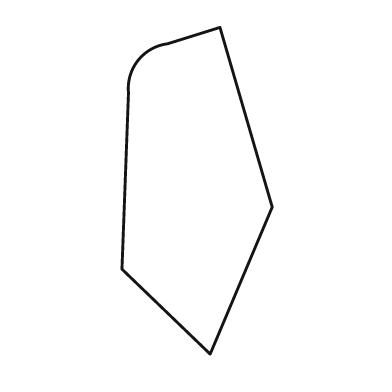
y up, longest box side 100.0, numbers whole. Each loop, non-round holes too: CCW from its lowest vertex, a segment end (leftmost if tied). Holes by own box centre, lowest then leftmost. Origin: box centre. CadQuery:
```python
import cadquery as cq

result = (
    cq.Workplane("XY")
    .moveTo(4.0, -50.0)
    .lineTo(23.0, -5.0)
    .lineTo(7.0, 50.0)
    .lineTo(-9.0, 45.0)
    .threePointArc((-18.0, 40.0), (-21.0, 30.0))
    .lineTo(-23.0, -24.0)
    .close()
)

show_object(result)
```